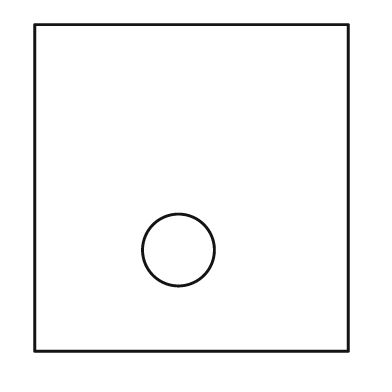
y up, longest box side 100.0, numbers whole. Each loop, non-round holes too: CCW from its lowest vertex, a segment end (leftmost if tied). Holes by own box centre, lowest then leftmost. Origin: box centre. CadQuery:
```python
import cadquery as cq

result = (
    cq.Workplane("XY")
    .moveTo(-48.0, -50.0)
    .lineTo(48.0, -50.0)
    .lineTo(48.0, 50.0)
    .lineTo(-48.0, 50.0)
    .close()
    .moveTo(-4.0, -19.0)
    .circle(11.0)
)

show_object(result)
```